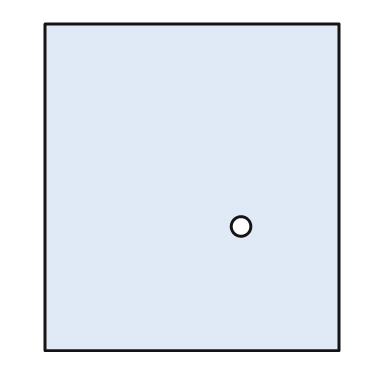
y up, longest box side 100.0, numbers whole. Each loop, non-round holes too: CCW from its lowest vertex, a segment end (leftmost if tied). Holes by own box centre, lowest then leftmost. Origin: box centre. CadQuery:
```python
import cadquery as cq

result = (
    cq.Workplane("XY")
    .moveTo(-45.0, -50.0)
    .lineTo(45.0, -50.0)
    .lineTo(45.0, 50.0)
    .lineTo(-45.0, 50.0)
    .close()
    .moveTo(15.0, -12.0)
    .circle(3.0)
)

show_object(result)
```